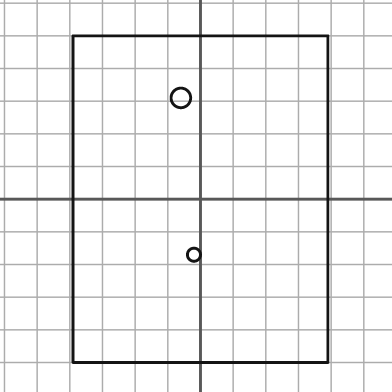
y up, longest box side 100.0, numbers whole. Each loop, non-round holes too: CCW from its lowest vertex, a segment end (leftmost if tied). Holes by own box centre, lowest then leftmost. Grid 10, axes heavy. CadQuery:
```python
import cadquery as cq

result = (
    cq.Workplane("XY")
    .moveTo(-39.0, -50.0)
    .lineTo(39.0, -50.0)
    .lineTo(39.0, 50.0)
    .lineTo(-39.0, 50.0)
    .close()
    .moveTo(-2.0, -17.0)
    .circle(2.0)
    .moveTo(-6.0, 31.0)
    .circle(3.0)
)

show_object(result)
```